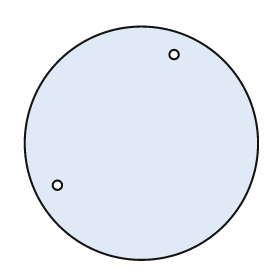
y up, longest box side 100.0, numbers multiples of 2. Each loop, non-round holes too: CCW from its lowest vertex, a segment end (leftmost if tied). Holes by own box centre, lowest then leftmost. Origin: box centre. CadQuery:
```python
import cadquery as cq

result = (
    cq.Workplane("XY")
    .moveTo(0.0, 0.0)
    .circle(50.0)
    .moveTo(-36.0, -18.0)
    .circle(2.0)
    .moveTo(14.0, 38.0)
    .circle(2.0)
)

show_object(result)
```